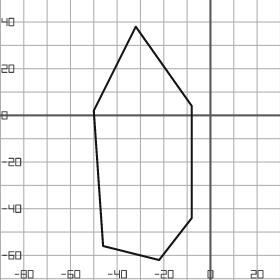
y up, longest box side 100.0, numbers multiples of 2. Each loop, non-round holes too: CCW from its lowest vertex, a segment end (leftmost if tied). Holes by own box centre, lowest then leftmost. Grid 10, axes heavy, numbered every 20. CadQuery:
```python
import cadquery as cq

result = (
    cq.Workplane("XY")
    .moveTo(-22.0, -62.0)
    .lineTo(-8.0, -44.0)
    .lineTo(-8.0, 4.0)
    .lineTo(-32.0, 38.0)
    .lineTo(-50.0, 2.0)
    .lineTo(-46.0, -56.0)
    .close()
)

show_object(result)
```